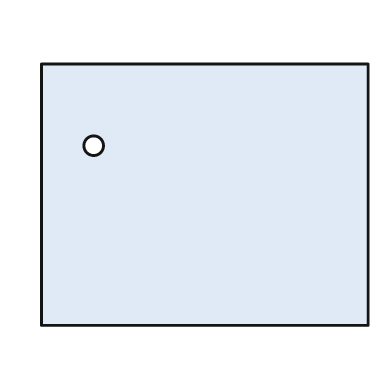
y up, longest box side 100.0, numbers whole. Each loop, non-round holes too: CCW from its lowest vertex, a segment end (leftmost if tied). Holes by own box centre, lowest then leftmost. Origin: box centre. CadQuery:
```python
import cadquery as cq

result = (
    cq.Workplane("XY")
    .moveTo(-50.0, -40.0)
    .lineTo(50.0, -40.0)
    .lineTo(50.0, 40.0)
    .lineTo(-50.0, 40.0)
    .close()
    .moveTo(-34.0, 15.0)
    .circle(3.0)
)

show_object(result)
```